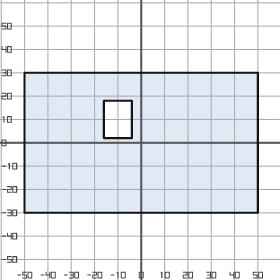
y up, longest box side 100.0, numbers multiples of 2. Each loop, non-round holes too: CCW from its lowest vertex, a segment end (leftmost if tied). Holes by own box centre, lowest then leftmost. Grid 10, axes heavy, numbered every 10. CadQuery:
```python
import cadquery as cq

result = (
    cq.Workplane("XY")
    .moveTo(-50.0, -30.0)
    .lineTo(50.0, -30.0)
    .lineTo(50.0, 30.0)
    .lineTo(-50.0, 30.0)
    .close()
    .moveTo(-16.0, 2.0)
    .lineTo(-4.0, 2.0)
    .lineTo(-4.0, 18.0)
    .lineTo(-16.0, 18.0)
    .close()
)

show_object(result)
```